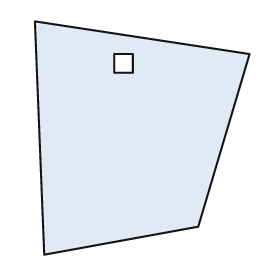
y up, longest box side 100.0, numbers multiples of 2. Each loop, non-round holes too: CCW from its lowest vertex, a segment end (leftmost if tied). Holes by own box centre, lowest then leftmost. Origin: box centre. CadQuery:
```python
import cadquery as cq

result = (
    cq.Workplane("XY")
    .moveTo(-42.0, -50.0)
    .lineTo(24.0, -38.0)
    .lineTo(46.0, 36.0)
    .lineTo(-46.0, 50.0)
    .close()
    .moveTo(-12.0, 28.0)
    .lineTo(-4.0, 28.0)
    .lineTo(-4.0, 36.0)
    .lineTo(-12.0, 36.0)
    .close()
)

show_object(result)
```